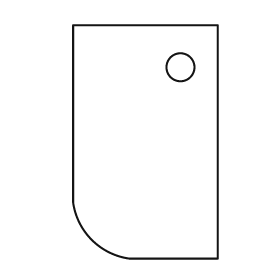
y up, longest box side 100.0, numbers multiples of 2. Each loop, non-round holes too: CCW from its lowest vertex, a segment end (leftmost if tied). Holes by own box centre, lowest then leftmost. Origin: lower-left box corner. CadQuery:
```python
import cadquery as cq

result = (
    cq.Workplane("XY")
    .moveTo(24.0, 0.0)
    .lineTo(62.0, 0.0)
    .lineTo(62.0, 100.0)
    .lineTo(0.0, 100.0)
    .lineTo(0.0, 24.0)
    .threePointArc((8.0, 8.0), (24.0, 0.0))
    .close()
    .moveTo(46.0, 82.0)
    .circle(6.0)
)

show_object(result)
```